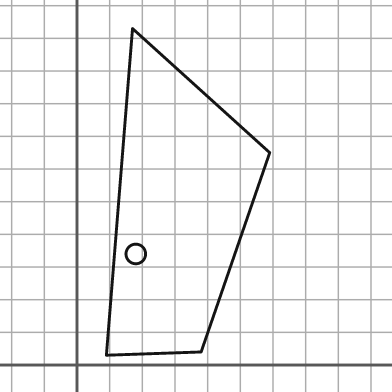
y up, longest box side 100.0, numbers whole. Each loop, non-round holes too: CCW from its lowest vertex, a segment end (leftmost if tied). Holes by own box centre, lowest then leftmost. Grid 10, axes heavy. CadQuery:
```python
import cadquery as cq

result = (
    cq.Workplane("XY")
    .moveTo(9.0, 3.0)
    .lineTo(38.0, 4.0)
    .lineTo(59.0, 65.0)
    .lineTo(17.0, 103.0)
    .close()
    .moveTo(18.0, 34.0)
    .circle(3.0)
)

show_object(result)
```